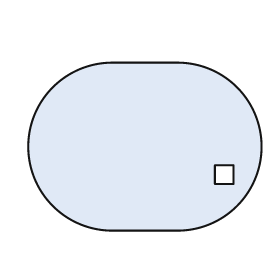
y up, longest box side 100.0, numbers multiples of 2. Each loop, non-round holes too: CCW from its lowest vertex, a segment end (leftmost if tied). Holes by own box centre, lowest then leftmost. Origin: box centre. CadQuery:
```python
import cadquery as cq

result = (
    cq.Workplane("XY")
    .moveTo(-14.0, -36.0)
    .lineTo(14.0, -36.0)
    .threePointArc((50.0, 0.0), (14.0, 36.0))
    .lineTo(-14.0, 36.0)
    .threePointArc((-50.0, 0.0), (-14.0, -36.0))
    .close()
    .moveTo(30.0, -16.0)
    .lineTo(38.0, -16.0)
    .lineTo(38.0, -8.0)
    .lineTo(30.0, -8.0)
    .close()
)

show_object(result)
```